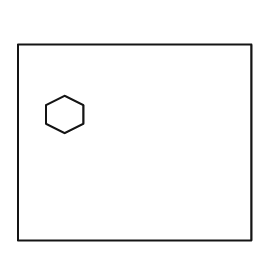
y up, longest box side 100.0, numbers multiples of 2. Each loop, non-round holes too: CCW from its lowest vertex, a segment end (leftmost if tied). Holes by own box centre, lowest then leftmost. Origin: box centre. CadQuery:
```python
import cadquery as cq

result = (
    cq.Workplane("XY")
    .moveTo(-50.0, -42.0)
    .lineTo(50.0, -42.0)
    .lineTo(50.0, 42.0)
    .lineTo(-50.0, 42.0)
    .close()
    .moveTo(-30.0, 4.0)
    .lineTo(-22.0, 8.0)
    .lineTo(-22.0, 16.0)
    .lineTo(-30.0, 20.0)
    .lineTo(-38.0, 16.0)
    .lineTo(-38.0, 8.0)
    .close()
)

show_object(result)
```